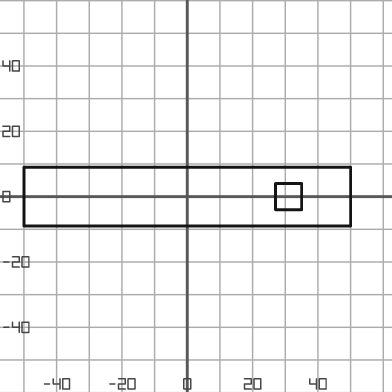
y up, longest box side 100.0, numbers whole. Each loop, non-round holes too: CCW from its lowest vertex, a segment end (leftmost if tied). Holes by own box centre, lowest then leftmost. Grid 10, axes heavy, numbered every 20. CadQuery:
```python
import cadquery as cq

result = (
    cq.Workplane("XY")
    .moveTo(-50.0, -9.0)
    .lineTo(50.0, -9.0)
    .lineTo(50.0, 9.0)
    .lineTo(-50.0, 9.0)
    .close()
    .moveTo(27.0, -4.0)
    .lineTo(35.0, -4.0)
    .lineTo(35.0, 4.0)
    .lineTo(27.0, 4.0)
    .close()
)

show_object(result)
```